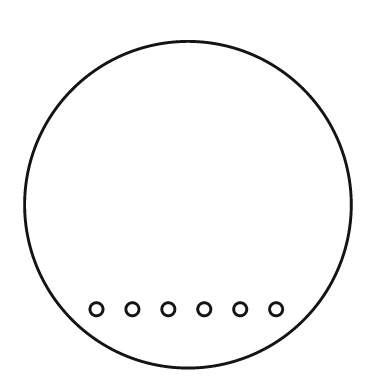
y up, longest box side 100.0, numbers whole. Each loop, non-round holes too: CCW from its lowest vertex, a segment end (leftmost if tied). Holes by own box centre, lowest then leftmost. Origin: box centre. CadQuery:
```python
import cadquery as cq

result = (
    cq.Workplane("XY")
    .moveTo(0.0, 0.0)
    .circle(50.0)
    .moveTo(-28.0, -32.0)
    .circle(2.0)
    .moveTo(-17.0, -32.0)
    .circle(2.0)
    .moveTo(-6.0, -32.0)
    .circle(2.0)
    .moveTo(5.0, -32.0)
    .circle(2.0)
    .moveTo(16.0, -32.0)
    .circle(2.0)
    .moveTo(27.0, -32.0)
    .circle(2.0)
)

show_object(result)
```